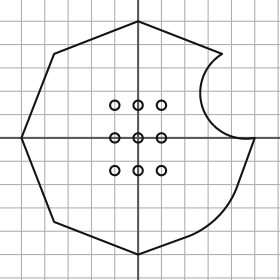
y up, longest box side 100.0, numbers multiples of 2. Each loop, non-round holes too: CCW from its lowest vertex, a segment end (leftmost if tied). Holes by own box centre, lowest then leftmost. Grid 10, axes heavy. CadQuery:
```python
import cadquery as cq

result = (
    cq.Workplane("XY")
    .moveTo(0.0, -50.0)
    .lineTo(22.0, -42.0)
    .threePointArc((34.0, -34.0), (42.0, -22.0))
    .lineTo(50.0, 0.0)
    .threePointArc((28.0, 12.0), (36.0, 36.0))
    .lineTo(0.0, 50.0)
    .lineTo(-36.0, 36.0)
    .lineTo(-50.0, 0.0)
    .lineTo(-36.0, -36.0)
    .close()
    .moveTo(-10.0, -14.0)
    .circle(2.0)
    .moveTo(0.0, -14.0)
    .circle(2.0)
    .moveTo(10.0, -14.0)
    .circle(2.0)
    .moveTo(-10.0, 0.0)
    .circle(2.0)
    .moveTo(0.0, 0.0)
    .circle(2.0)
    .moveTo(10.0, 0.0)
    .circle(2.0)
    .moveTo(-10.0, 14.0)
    .circle(2.0)
    .moveTo(0.0, 14.0)
    .circle(2.0)
    .moveTo(10.0, 14.0)
    .circle(2.0)
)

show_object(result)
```